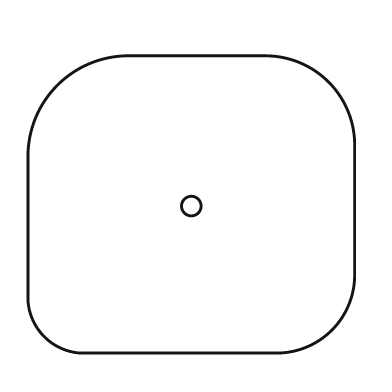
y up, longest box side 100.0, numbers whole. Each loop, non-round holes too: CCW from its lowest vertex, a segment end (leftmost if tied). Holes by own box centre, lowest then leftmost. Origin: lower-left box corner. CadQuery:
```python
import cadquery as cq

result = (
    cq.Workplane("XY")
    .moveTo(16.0, 0.0)
    .lineTo(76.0, 0.0)
    .threePointArc((93.0, 7.0), (100.0, 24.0))
    .lineTo(100.0, 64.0)
    .threePointArc((92.0, 83.0), (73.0, 91.0))
    .lineTo(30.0, 91.0)
    .threePointArc((9.0, 82.0), (0.0, 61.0))
    .lineTo(0.0, 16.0)
    .threePointArc((5.0, 5.0), (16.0, 0.0))
    .close()
    .moveTo(50.0, 45.0)
    .circle(3.0)
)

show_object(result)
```